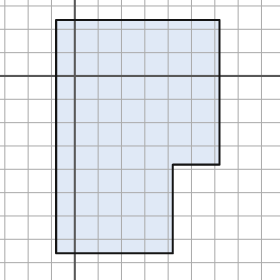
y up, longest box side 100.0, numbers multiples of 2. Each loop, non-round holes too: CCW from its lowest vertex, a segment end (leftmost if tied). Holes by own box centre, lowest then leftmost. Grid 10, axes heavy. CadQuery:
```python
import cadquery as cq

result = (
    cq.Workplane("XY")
    .moveTo(-8.0, -76.0)
    .lineTo(42.0, -76.0)
    .lineTo(42.0, -38.0)
    .lineTo(62.0, -38.0)
    .lineTo(62.0, 24.0)
    .lineTo(-8.0, 24.0)
    .close()
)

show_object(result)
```